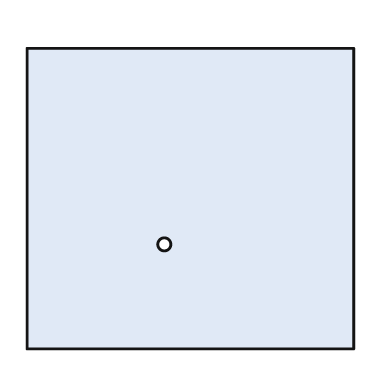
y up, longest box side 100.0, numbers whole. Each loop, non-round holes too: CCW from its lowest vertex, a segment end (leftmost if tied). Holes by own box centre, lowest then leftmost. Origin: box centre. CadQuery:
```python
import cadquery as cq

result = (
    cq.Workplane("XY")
    .moveTo(-50.0, -46.0)
    .lineTo(50.0, -46.0)
    .lineTo(50.0, 46.0)
    .lineTo(-50.0, 46.0)
    .close()
    .moveTo(-8.0, -14.0)
    .circle(2.0)
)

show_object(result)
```